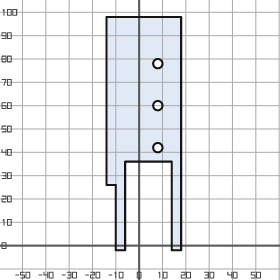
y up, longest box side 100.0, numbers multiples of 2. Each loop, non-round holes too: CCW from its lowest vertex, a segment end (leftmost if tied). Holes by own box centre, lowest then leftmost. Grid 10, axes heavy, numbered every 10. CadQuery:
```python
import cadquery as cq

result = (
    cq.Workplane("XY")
    .moveTo(-10.0, -2.0)
    .lineTo(-6.0, -2.0)
    .lineTo(-6.0, 36.0)
    .lineTo(14.0, 36.0)
    .lineTo(14.0, -2.0)
    .lineTo(18.0, -2.0)
    .lineTo(18.0, 98.0)
    .lineTo(-14.0, 98.0)
    .lineTo(-14.0, 26.0)
    .lineTo(-10.0, 26.0)
    .close()
    .moveTo(8.0, 42.0)
    .circle(2.0)
    .moveTo(8.0, 60.0)
    .circle(2.0)
    .moveTo(8.0, 78.0)
    .circle(2.0)
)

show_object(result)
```